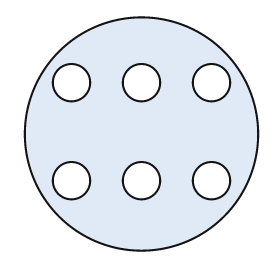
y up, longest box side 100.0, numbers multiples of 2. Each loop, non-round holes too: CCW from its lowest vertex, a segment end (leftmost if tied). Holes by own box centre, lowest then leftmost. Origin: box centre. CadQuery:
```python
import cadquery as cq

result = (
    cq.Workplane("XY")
    .moveTo(0.0, 0.0)
    .circle(50.0)
    .moveTo(-30.0, -20.0)
    .circle(8.0)
    .moveTo(0.0, -20.0)
    .circle(8.0)
    .moveTo(30.0, -20.0)
    .circle(8.0)
    .moveTo(-30.0, 22.0)
    .circle(8.0)
    .moveTo(0.0, 22.0)
    .circle(8.0)
    .moveTo(30.0, 22.0)
    .circle(8.0)
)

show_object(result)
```